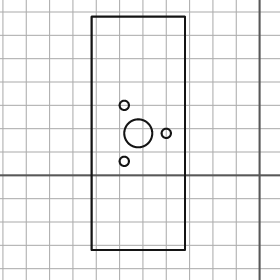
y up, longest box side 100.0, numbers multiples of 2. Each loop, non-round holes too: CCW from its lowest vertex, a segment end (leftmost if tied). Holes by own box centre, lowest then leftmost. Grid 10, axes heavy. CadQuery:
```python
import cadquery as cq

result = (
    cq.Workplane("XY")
    .moveTo(-72.0, -32.0)
    .lineTo(-32.0, -32.0)
    .lineTo(-32.0, 68.0)
    .lineTo(-72.0, 68.0)
    .close()
    .moveTo(-58.0, 6.0)
    .circle(2.0)
    .moveTo(-52.0, 18.0)
    .circle(6.0)
    .moveTo(-40.0, 18.0)
    .circle(2.0)
    .moveTo(-58.0, 30.0)
    .circle(2.0)
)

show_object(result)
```